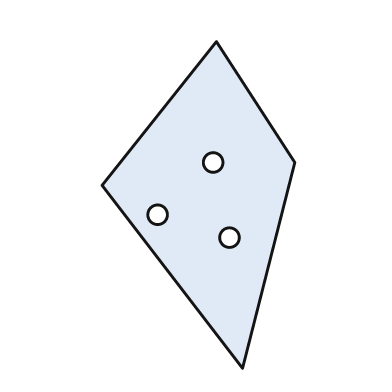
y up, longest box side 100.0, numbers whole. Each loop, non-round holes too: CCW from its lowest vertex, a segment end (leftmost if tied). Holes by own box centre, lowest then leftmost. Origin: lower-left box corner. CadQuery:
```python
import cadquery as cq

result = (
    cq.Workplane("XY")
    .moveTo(43.0, 0.0)
    .lineTo(59.0, 63.0)
    .lineTo(35.0, 100.0)
    .lineTo(0.0, 56.0)
    .close()
    .moveTo(39.0, 40.0)
    .circle(3.0)
    .moveTo(17.0, 47.0)
    .circle(3.0)
    .moveTo(34.0, 63.0)
    .circle(3.0)
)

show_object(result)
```